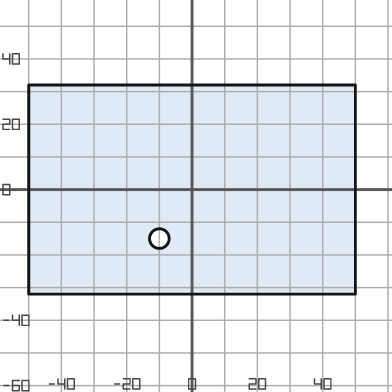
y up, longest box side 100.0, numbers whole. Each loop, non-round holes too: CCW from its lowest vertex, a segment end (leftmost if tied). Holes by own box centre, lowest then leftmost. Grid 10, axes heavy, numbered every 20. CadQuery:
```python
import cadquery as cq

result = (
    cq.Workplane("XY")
    .moveTo(-50.0, -32.0)
    .lineTo(50.0, -32.0)
    .lineTo(50.0, 32.0)
    .lineTo(-50.0, 32.0)
    .close()
    .moveTo(-10.0, -15.0)
    .circle(3.0)
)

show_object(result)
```